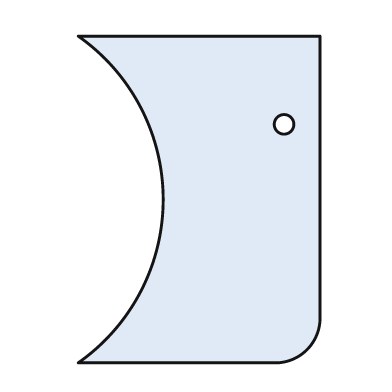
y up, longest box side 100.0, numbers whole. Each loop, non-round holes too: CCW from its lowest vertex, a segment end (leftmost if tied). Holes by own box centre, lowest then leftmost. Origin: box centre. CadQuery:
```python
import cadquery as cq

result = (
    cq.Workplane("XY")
    .moveTo(-37.0, -50.0)
    .lineTo(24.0, -50.0)
    .threePointArc((33.0, -46.0), (37.0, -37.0))
    .lineTo(37.0, 50.0)
    .lineTo(-37.0, 50.0)
    .threePointArc((-11.0, 0.0), (-37.0, -50.0))
    .close()
    .moveTo(26.0, 23.0)
    .circle(3.0)
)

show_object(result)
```